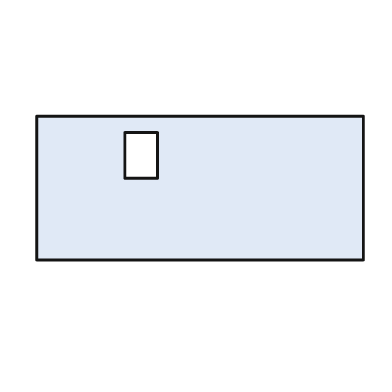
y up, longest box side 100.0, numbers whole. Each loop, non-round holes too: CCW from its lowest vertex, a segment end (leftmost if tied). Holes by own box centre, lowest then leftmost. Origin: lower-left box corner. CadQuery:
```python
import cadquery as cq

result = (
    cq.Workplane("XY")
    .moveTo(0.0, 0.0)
    .lineTo(100.0, 0.0)
    .lineTo(100.0, 44.0)
    .lineTo(0.0, 44.0)
    .close()
    .moveTo(27.0, 25.0)
    .lineTo(37.0, 25.0)
    .lineTo(37.0, 39.0)
    .lineTo(27.0, 39.0)
    .close()
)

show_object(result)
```